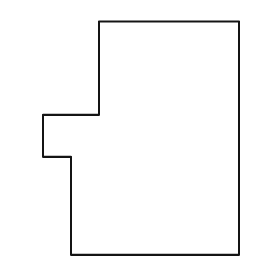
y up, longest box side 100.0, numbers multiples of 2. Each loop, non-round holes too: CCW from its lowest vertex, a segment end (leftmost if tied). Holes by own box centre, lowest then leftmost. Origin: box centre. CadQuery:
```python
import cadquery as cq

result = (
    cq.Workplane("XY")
    .moveTo(-30.0, -50.0)
    .lineTo(42.0, -50.0)
    .lineTo(42.0, 50.0)
    .lineTo(-18.0, 50.0)
    .lineTo(-18.0, 10.0)
    .lineTo(-42.0, 10.0)
    .lineTo(-42.0, -8.0)
    .lineTo(-30.0, -8.0)
    .close()
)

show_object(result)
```